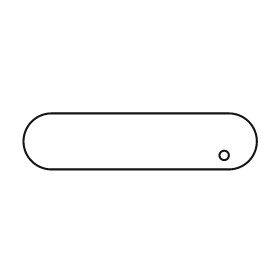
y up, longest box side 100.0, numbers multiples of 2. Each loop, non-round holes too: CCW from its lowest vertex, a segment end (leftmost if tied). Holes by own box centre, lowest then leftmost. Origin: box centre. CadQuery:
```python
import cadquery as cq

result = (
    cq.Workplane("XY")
    .moveTo(-38.0, -12.0)
    .lineTo(38.0, -12.0)
    .threePointArc((50.0, 0.0), (38.0, 12.0))
    .lineTo(-38.0, 12.0)
    .threePointArc((-50.0, 0.0), (-38.0, -12.0))
    .close()
    .moveTo(36.0, -6.0)
    .circle(2.0)
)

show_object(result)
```